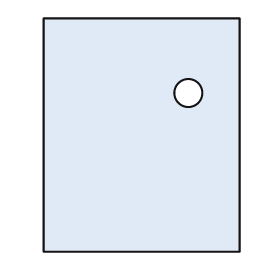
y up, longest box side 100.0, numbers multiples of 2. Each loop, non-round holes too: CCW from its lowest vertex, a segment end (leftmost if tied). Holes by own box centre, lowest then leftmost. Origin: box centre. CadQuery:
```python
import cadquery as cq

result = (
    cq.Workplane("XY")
    .moveTo(-42.0, -50.0)
    .lineTo(42.0, -50.0)
    .lineTo(42.0, 50.0)
    .lineTo(-42.0, 50.0)
    .close()
    .moveTo(20.0, 18.0)
    .circle(6.0)
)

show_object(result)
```